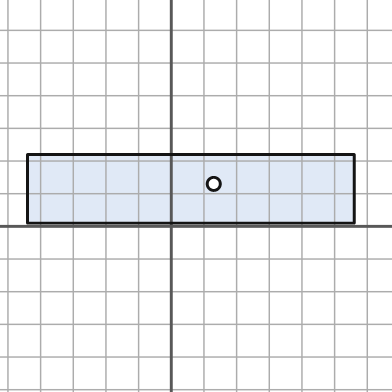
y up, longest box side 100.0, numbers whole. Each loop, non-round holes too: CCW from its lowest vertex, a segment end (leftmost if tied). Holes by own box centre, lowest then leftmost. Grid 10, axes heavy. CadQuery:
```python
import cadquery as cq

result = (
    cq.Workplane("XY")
    .moveTo(-44.0, 1.0)
    .lineTo(56.0, 1.0)
    .lineTo(56.0, 22.0)
    .lineTo(-44.0, 22.0)
    .close()
    .moveTo(13.0, 13.0)
    .circle(2.0)
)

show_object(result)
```